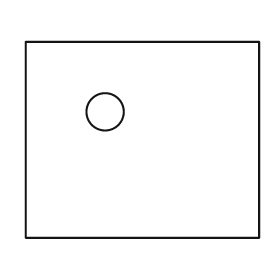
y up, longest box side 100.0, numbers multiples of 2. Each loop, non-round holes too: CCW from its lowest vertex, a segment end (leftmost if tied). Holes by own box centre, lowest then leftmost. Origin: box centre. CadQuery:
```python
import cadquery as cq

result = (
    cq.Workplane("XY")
    .moveTo(-50.0, -42.0)
    .lineTo(50.0, -42.0)
    .lineTo(50.0, 42.0)
    .lineTo(-50.0, 42.0)
    .close()
    .moveTo(-16.0, 12.0)
    .circle(8.0)
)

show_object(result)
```